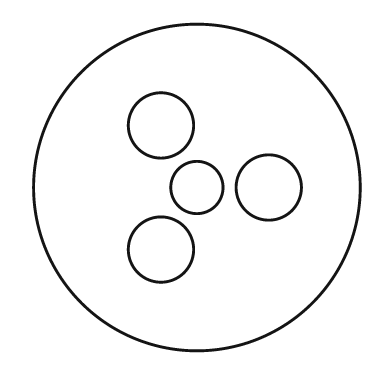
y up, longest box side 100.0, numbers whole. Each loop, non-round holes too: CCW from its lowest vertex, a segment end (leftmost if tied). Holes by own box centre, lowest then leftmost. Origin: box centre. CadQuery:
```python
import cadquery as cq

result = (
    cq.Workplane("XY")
    .moveTo(0.0, 0.0)
    .circle(50.0)
    .moveTo(-11.0, -19.0)
    .circle(10.0)
    .moveTo(0.0, 0.0)
    .circle(8.0)
    .moveTo(22.0, 0.0)
    .circle(10.0)
    .moveTo(-11.0, 19.0)
    .circle(10.0)
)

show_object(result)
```